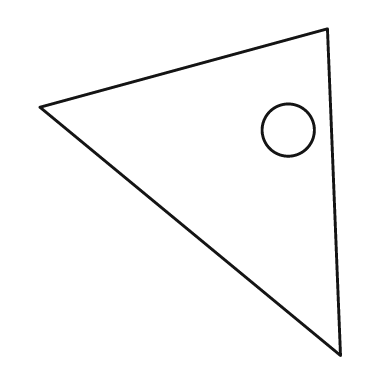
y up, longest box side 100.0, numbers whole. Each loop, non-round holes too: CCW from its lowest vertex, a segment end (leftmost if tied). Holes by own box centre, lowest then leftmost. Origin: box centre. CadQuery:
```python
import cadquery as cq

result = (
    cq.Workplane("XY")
    .moveTo(46.0, -50.0)
    .lineTo(42.0, 50.0)
    .lineTo(-46.0, 26.0)
    .close()
    .moveTo(30.0, 19.0)
    .circle(8.0)
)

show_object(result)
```